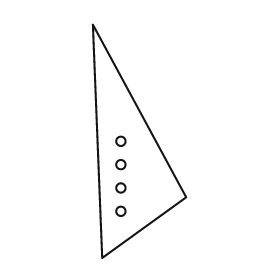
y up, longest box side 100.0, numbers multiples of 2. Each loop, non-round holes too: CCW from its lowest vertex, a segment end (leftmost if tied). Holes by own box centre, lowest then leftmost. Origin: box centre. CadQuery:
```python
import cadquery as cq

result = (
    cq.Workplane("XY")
    .moveTo(-16.0, -50.0)
    .lineTo(20.0, -24.0)
    .lineTo(-20.0, 50.0)
    .close()
    .moveTo(-8.0, -30.0)
    .circle(2.0)
    .moveTo(-8.0, -20.0)
    .circle(2.0)
    .moveTo(-8.0, -10.0)
    .circle(2.0)
    .moveTo(-8.0, 0.0)
    .circle(2.0)
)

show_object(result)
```